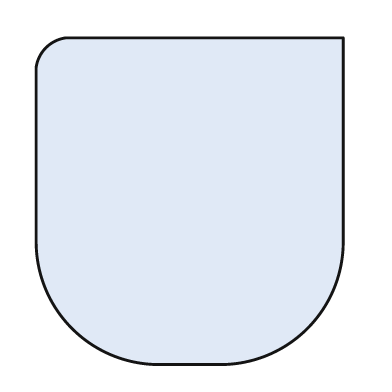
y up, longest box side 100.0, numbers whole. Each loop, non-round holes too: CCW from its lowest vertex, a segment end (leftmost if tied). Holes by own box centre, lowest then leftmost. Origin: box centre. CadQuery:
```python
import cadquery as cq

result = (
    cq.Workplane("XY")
    .moveTo(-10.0, -50.0)
    .lineTo(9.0, -50.0)
    .threePointArc((36.0, -39.0), (47.0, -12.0))
    .lineTo(47.0, 50.0)
    .lineTo(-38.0, 50.0)
    .threePointArc((-44.0, 47.0), (-47.0, 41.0))
    .lineTo(-47.0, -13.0)
    .threePointArc((-36.0, -39.0), (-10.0, -50.0))
    .close()
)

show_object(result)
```